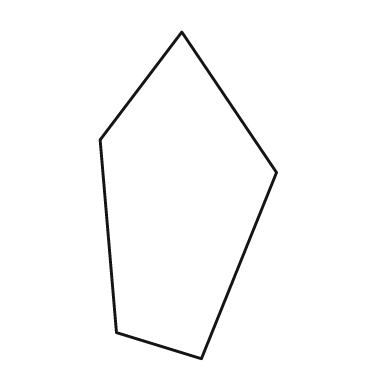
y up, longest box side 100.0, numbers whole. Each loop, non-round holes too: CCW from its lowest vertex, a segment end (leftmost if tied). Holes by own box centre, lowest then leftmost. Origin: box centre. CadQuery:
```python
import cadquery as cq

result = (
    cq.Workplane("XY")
    .moveTo(4.0, -50.0)
    .lineTo(27.0, 7.0)
    .lineTo(-2.0, 50.0)
    .lineTo(-27.0, 17.0)
    .lineTo(-22.0, -42.0)
    .close()
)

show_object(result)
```